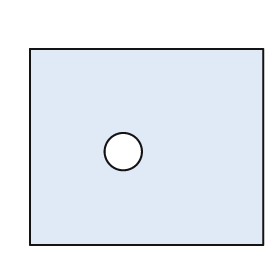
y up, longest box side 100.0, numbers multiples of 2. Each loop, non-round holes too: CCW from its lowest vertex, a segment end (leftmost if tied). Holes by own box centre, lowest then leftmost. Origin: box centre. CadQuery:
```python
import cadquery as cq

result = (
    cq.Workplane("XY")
    .moveTo(-50.0, -42.0)
    .lineTo(50.0, -42.0)
    .lineTo(50.0, 42.0)
    .lineTo(-50.0, 42.0)
    .close()
    .moveTo(-10.0, -2.0)
    .circle(8.0)
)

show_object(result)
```